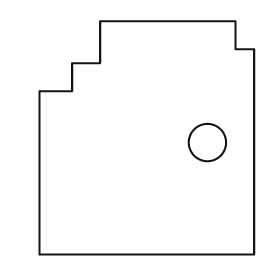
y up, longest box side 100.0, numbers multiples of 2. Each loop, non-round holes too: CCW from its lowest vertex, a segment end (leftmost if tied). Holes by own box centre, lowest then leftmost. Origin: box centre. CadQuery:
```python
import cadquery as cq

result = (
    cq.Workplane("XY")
    .moveTo(-46.0, -50.0)
    .lineTo(46.0, -50.0)
    .lineTo(46.0, 38.0)
    .lineTo(38.0, 38.0)
    .lineTo(38.0, 50.0)
    .lineTo(-20.0, 50.0)
    .lineTo(-20.0, 32.0)
    .lineTo(-32.0, 32.0)
    .lineTo(-32.0, 20.0)
    .lineTo(-46.0, 20.0)
    .close()
    .moveTo(26.0, -2.0)
    .circle(8.0)
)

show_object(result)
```